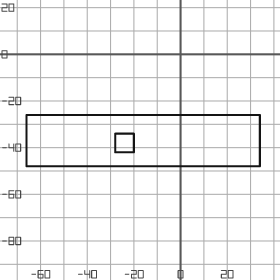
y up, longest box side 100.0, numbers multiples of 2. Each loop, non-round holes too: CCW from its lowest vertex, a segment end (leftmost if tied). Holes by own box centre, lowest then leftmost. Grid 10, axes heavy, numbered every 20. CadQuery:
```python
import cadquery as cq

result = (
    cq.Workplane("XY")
    .moveTo(-66.0, -48.0)
    .lineTo(34.0, -48.0)
    .lineTo(34.0, -26.0)
    .lineTo(-66.0, -26.0)
    .close()
    .moveTo(-28.0, -42.0)
    .lineTo(-20.0, -42.0)
    .lineTo(-20.0, -34.0)
    .lineTo(-28.0, -34.0)
    .close()
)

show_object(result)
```